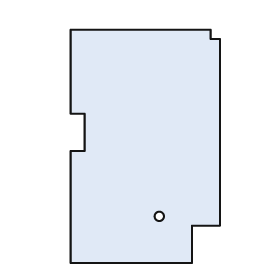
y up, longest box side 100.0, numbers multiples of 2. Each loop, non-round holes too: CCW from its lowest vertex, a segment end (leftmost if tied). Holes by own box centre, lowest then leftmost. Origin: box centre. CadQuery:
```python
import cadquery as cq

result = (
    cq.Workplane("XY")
    .moveTo(-32.0, -50.0)
    .lineTo(20.0, -50.0)
    .lineTo(20.0, -34.0)
    .lineTo(32.0, -34.0)
    .lineTo(32.0, 46.0)
    .lineTo(28.0, 46.0)
    .lineTo(28.0, 50.0)
    .lineTo(-32.0, 50.0)
    .lineTo(-32.0, 14.0)
    .lineTo(-26.0, 14.0)
    .lineTo(-26.0, -2.0)
    .lineTo(-32.0, -2.0)
    .close()
    .moveTo(6.0, -30.0)
    .circle(2.0)
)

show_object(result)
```